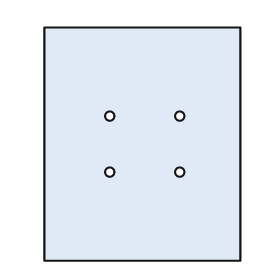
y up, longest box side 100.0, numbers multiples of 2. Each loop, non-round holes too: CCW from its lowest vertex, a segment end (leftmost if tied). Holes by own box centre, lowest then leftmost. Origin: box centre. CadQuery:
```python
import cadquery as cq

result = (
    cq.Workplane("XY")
    .moveTo(-42.0, -50.0)
    .lineTo(42.0, -50.0)
    .lineTo(42.0, 50.0)
    .lineTo(-42.0, 50.0)
    .close()
    .moveTo(-14.0, -12.0)
    .circle(2.0)
    .moveTo(16.0, -12.0)
    .circle(2.0)
    .moveTo(-14.0, 12.0)
    .circle(2.0)
    .moveTo(16.0, 12.0)
    .circle(2.0)
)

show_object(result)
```